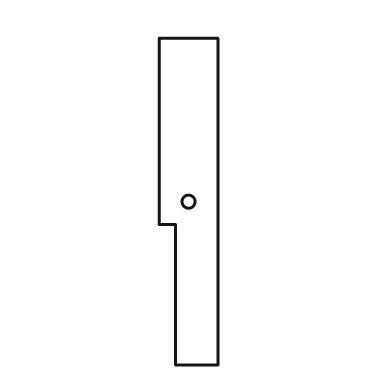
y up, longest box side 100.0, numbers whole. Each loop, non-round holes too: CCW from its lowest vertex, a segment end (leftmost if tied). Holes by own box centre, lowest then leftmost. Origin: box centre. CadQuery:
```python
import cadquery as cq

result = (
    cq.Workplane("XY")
    .moveTo(-4.0, -50.0)
    .lineTo(9.0, -50.0)
    .lineTo(9.0, 50.0)
    .lineTo(-9.0, 50.0)
    .lineTo(-9.0, -7.0)
    .lineTo(-4.0, -7.0)
    .close()
    .moveTo(0.0, 0.0)
    .circle(2.0)
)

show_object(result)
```